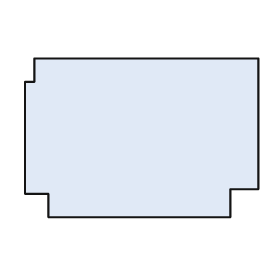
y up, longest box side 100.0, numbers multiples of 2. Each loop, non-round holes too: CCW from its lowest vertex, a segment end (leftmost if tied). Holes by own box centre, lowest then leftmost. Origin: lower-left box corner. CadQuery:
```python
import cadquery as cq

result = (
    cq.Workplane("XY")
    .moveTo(10.0, 0.0)
    .lineTo(88.0, 0.0)
    .lineTo(88.0, 12.0)
    .lineTo(100.0, 12.0)
    .lineTo(100.0, 68.0)
    .lineTo(4.0, 68.0)
    .lineTo(4.0, 58.0)
    .lineTo(0.0, 58.0)
    .lineTo(0.0, 10.0)
    .lineTo(10.0, 10.0)
    .close()
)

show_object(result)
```